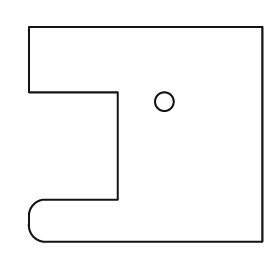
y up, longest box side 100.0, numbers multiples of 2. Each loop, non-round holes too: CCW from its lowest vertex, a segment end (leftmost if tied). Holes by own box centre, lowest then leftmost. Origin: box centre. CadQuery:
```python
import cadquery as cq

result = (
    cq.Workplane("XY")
    .moveTo(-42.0, -46.0)
    .lineTo(50.0, -46.0)
    .lineTo(50.0, 46.0)
    .lineTo(-50.0, 46.0)
    .lineTo(-50.0, 18.0)
    .lineTo(-12.0, 18.0)
    .lineTo(-12.0, -28.0)
    .lineTo(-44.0, -28.0)
    .threePointArc((-48.0, -30.0), (-50.0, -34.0))
    .lineTo(-50.0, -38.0)
    .threePointArc((-48.0, -44.0), (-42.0, -46.0))
    .close()
    .moveTo(8.0, 14.0)
    .circle(4.0)
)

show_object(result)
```